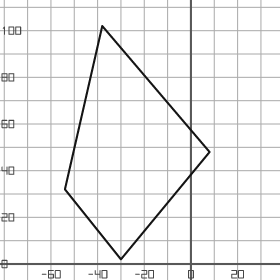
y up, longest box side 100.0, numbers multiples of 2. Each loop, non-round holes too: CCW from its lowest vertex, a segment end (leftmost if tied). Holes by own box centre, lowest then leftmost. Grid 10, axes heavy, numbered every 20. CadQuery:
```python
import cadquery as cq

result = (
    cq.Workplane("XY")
    .moveTo(-30.0, 2.0)
    .lineTo(8.0, 48.0)
    .lineTo(-38.0, 102.0)
    .lineTo(-54.0, 32.0)
    .close()
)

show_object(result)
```